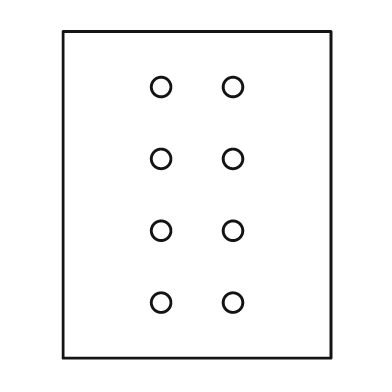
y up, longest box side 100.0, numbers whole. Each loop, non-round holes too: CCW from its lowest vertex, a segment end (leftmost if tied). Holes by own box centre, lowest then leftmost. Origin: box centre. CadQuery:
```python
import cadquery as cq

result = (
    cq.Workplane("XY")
    .moveTo(-41.0, -50.0)
    .lineTo(41.0, -50.0)
    .lineTo(41.0, 50.0)
    .lineTo(-41.0, 50.0)
    .close()
    .moveTo(-11.0, -33.0)
    .circle(3.0)
    .moveTo(11.0, -33.0)
    .circle(3.0)
    .moveTo(-11.0, -11.0)
    .circle(3.0)
    .moveTo(11.0, -11.0)
    .circle(3.0)
    .moveTo(-11.0, 11.0)
    .circle(3.0)
    .moveTo(11.0, 11.0)
    .circle(3.0)
    .moveTo(-11.0, 33.0)
    .circle(3.0)
    .moveTo(11.0, 33.0)
    .circle(3.0)
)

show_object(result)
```